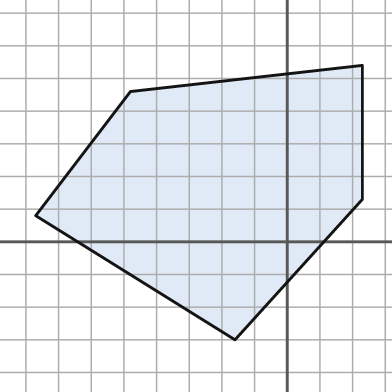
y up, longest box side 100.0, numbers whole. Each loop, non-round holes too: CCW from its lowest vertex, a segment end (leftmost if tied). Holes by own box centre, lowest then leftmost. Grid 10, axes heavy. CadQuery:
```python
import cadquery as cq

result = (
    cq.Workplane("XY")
    .moveTo(-16.0, -30.0)
    .lineTo(23.0, 13.0)
    .lineTo(23.0, 54.0)
    .lineTo(-48.0, 46.0)
    .lineTo(-77.0, 8.0)
    .close()
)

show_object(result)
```